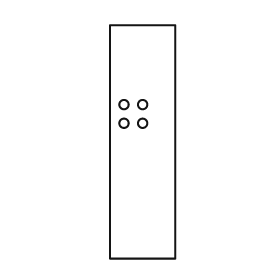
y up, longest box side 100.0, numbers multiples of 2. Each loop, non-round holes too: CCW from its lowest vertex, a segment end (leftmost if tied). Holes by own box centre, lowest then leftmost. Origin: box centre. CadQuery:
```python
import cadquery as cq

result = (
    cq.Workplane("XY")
    .moveTo(-14.0, -50.0)
    .lineTo(14.0, -50.0)
    .lineTo(14.0, 50.0)
    .lineTo(-14.0, 50.0)
    .close()
    .moveTo(-8.0, 8.0)
    .circle(2.0)
    .moveTo(0.0, 8.0)
    .circle(2.0)
    .moveTo(-8.0, 16.0)
    .circle(2.0)
    .moveTo(0.0, 16.0)
    .circle(2.0)
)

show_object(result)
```